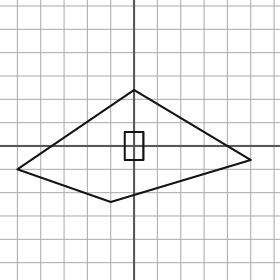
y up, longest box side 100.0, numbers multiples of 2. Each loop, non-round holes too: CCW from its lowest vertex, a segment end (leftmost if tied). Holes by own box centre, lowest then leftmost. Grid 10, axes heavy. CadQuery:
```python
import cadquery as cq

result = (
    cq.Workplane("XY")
    .moveTo(-10.0, -24.0)
    .lineTo(50.0, -6.0)
    .lineTo(0.0, 24.0)
    .lineTo(-50.0, -10.0)
    .close()
    .moveTo(-4.0, -6.0)
    .lineTo(4.0, -6.0)
    .lineTo(4.0, 6.0)
    .lineTo(-4.0, 6.0)
    .close()
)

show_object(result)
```